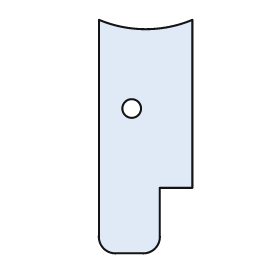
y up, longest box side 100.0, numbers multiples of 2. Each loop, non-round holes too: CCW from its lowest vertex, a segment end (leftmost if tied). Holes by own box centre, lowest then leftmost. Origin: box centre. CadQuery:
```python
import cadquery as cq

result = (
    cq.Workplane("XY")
    .moveTo(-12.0, -50.0)
    .lineTo(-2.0, -50.0)
    .threePointArc((4.0, -48.0), (6.0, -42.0))
    .lineTo(6.0, -22.0)
    .lineTo(20.0, -22.0)
    .lineTo(20.0, 50.0)
    .threePointArc((0.0, 46.0), (-20.0, 50.0))
    .lineTo(-20.0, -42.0)
    .threePointArc((-18.0, -48.0), (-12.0, -50.0))
    .close()
    .moveTo(-6.0, 12.0)
    .circle(4.0)
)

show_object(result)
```